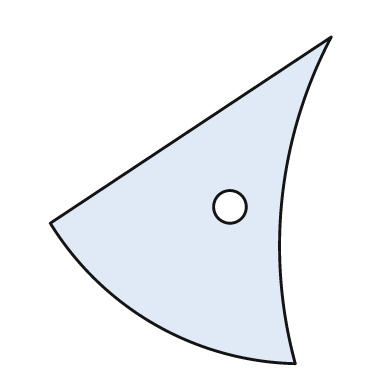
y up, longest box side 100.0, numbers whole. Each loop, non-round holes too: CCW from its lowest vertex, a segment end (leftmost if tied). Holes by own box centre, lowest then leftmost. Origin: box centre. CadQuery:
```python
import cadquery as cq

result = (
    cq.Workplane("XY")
    .moveTo(32.0, -50.0)
    .threePointArc((28.0, 1.0), (43.0, 50.0))
    .lineTo(-43.0, -7.0)
    .threePointArc((-11.0, -38.0), (32.0, -50.0))
    .close()
    .moveTo(12.0, -2.0)
    .circle(5.0)
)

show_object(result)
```